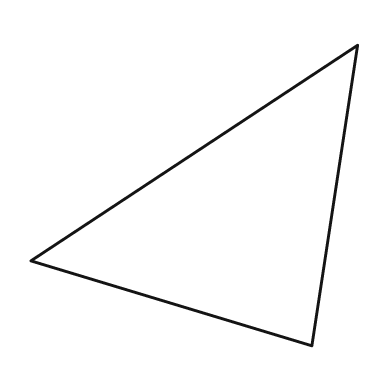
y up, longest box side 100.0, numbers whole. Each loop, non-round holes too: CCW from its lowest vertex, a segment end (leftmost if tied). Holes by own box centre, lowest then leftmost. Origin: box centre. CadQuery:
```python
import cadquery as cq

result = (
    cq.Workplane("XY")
    .moveTo(36.0, -46.0)
    .lineTo(50.0, 46.0)
    .lineTo(-50.0, -20.0)
    .close()
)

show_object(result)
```